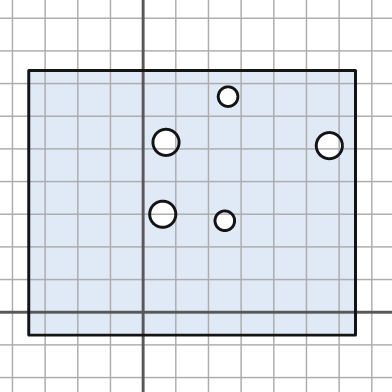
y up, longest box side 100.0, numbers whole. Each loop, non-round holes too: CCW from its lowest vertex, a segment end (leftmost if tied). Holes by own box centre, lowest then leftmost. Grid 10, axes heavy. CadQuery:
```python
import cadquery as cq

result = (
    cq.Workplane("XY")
    .moveTo(-35.0, -7.0)
    .lineTo(65.0, -7.0)
    .lineTo(65.0, 74.0)
    .lineTo(-35.0, 74.0)
    .close()
    .moveTo(25.0, 28.0)
    .circle(3.0)
    .moveTo(6.0, 30.0)
    .circle(4.0)
    .moveTo(57.0, 51.0)
    .circle(4.0)
    .moveTo(7.0, 52.0)
    .circle(4.0)
    .moveTo(26.0, 66.0)
    .circle(3.0)
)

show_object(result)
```